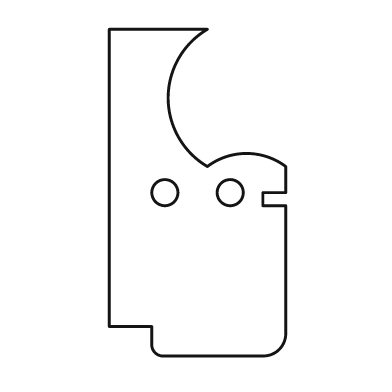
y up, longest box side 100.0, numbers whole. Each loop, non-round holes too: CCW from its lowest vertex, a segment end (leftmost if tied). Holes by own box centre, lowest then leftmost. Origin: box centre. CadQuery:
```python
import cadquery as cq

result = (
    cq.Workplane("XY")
    .moveTo(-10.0, -50.0)
    .lineTo(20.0, -50.0)
    .threePointArc((25.0, -48.0), (27.0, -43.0))
    .lineTo(27.0, -4.0)
    .lineTo(20.0, -4.0)
    .lineTo(20.0, 0.0)
    .lineTo(27.0, 0.0)
    .lineTo(27.0, 8.0)
    .threePointArc((15.0, 12.0), (3.0, 8.0))
    .threePointArc((-9.0, 29.0), (3.0, 50.0))
    .lineTo(-27.0, 50.0)
    .lineTo(-27.0, -41.0)
    .lineTo(-14.0, -41.0)
    .lineTo(-14.0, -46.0)
    .threePointArc((-13.0, -49.0), (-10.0, -50.0))
    .close()
    .moveTo(-10.0, 0.0)
    .circle(4.0)
    .moveTo(10.0, 0.0)
    .circle(4.0)
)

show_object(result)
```